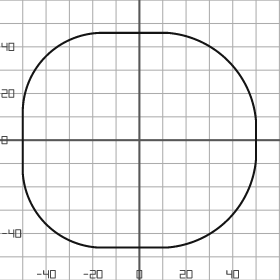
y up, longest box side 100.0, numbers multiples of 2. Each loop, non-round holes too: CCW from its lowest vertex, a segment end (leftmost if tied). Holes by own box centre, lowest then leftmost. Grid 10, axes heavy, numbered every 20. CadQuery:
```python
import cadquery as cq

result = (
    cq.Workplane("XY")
    .moveTo(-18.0, -46.0)
    .lineTo(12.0, -46.0)
    .threePointArc((38.0, -34.0), (50.0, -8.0))
    .lineTo(50.0, 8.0)
    .threePointArc((38.0, 34.0), (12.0, 46.0))
    .lineTo(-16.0, 46.0)
    .threePointArc((-40.0, 36.0), (-50.0, 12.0))
    .lineTo(-50.0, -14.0)
    .threePointArc((-40.0, -36.0), (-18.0, -46.0))
    .close()
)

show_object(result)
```